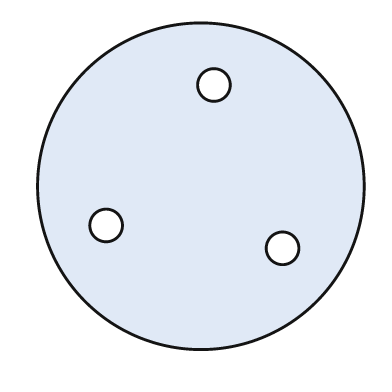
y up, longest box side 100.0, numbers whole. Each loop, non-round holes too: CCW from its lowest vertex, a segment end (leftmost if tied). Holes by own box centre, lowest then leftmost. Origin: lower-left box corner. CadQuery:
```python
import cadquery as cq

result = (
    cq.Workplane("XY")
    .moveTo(50.0, 50.0)
    .circle(50.0)
    .moveTo(75.0, 31.0)
    .circle(5.0)
    .moveTo(21.0, 38.0)
    .circle(5.0)
    .moveTo(54.0, 81.0)
    .circle(5.0)
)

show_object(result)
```